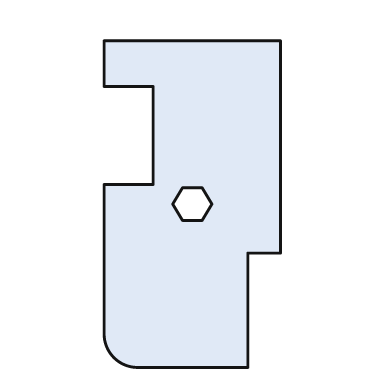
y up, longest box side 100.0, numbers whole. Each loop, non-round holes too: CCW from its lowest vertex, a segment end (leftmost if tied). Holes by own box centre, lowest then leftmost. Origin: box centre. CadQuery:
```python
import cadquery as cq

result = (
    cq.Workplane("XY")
    .moveTo(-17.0, -50.0)
    .lineTo(17.0, -50.0)
    .lineTo(17.0, -15.0)
    .lineTo(27.0, -15.0)
    .lineTo(27.0, 50.0)
    .lineTo(-27.0, 50.0)
    .lineTo(-27.0, 36.0)
    .lineTo(-12.0, 36.0)
    .lineTo(-12.0, 6.0)
    .lineTo(-27.0, 6.0)
    .lineTo(-27.0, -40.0)
    .threePointArc((-24.0, -47.0), (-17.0, -50.0))
    .close()
    .moveTo(-3.0, -5.0)
    .lineTo(3.0, -5.0)
    .lineTo(6.0, 0.0)
    .lineTo(3.0, 5.0)
    .lineTo(-3.0, 5.0)
    .lineTo(-6.0, 0.0)
    .close()
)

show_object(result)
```